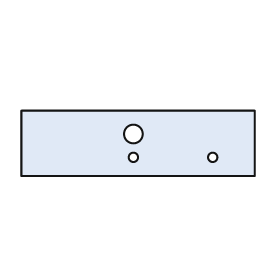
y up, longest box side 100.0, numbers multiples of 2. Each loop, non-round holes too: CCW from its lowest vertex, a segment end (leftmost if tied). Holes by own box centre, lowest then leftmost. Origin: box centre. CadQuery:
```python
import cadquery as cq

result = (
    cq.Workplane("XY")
    .moveTo(-50.0, -14.0)
    .lineTo(50.0, -14.0)
    .lineTo(50.0, 14.0)
    .lineTo(-50.0, 14.0)
    .close()
    .moveTo(-2.0, -6.0)
    .circle(2.0)
    .moveTo(32.0, -6.0)
    .circle(2.0)
    .moveTo(-2.0, 4.0)
    .circle(4.0)
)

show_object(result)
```